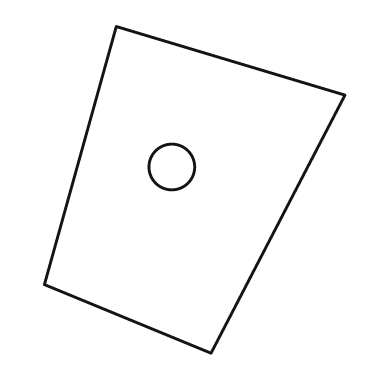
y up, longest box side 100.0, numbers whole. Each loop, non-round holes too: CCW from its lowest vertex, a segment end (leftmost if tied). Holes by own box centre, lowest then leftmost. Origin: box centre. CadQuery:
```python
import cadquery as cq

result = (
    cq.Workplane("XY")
    .moveTo(5.0, -50.0)
    .lineTo(46.0, 29.0)
    .lineTo(-24.0, 50.0)
    .lineTo(-46.0, -29.0)
    .close()
    .moveTo(-7.0, 7.0)
    .circle(7.0)
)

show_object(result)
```